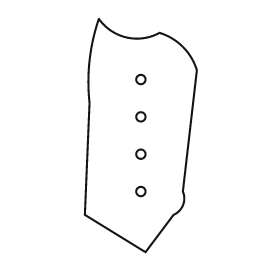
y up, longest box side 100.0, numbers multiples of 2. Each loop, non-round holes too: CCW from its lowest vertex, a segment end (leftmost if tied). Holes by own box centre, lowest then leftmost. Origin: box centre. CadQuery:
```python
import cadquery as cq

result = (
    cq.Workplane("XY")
    .moveTo(2.0, -50.0)
    .lineTo(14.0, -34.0)
    .threePointArc((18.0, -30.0), (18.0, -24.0))
    .lineTo(24.0, 28.0)
    .threePointArc((18.0, 38.0), (8.0, 44.0))
    .threePointArc((-6.0, 42.0), (-18.0, 50.0))
    .threePointArc((-22.0, 32.0), (-22.0, 14.0))
    .lineTo(-24.0, -34.0)
    .close()
    .moveTo(0.0, -24.0)
    .circle(2.0)
    .moveTo(0.0, -8.0)
    .circle(2.0)
    .moveTo(0.0, 8.0)
    .circle(2.0)
    .moveTo(0.0, 24.0)
    .circle(2.0)
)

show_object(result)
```